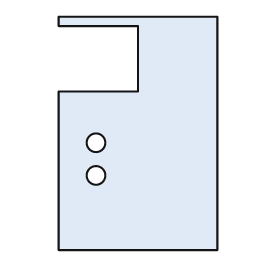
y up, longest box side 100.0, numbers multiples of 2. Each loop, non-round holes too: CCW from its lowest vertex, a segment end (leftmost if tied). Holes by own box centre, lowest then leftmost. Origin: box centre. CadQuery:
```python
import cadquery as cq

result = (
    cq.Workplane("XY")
    .moveTo(-34.0, -50.0)
    .lineTo(34.0, -50.0)
    .lineTo(34.0, 50.0)
    .lineTo(-34.0, 50.0)
    .lineTo(-34.0, 46.0)
    .lineTo(0.0, 46.0)
    .lineTo(0.0, 18.0)
    .lineTo(-34.0, 18.0)
    .close()
    .moveTo(-18.0, -18.0)
    .circle(4.0)
    .moveTo(-18.0, -4.0)
    .circle(4.0)
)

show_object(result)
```